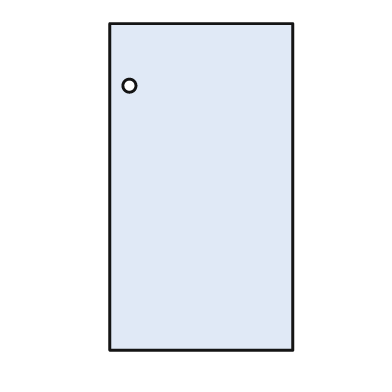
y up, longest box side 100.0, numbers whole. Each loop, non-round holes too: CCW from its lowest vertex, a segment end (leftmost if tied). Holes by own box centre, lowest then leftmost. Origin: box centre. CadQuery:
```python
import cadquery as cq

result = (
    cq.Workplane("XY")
    .moveTo(-28.0, -50.0)
    .lineTo(28.0, -50.0)
    .lineTo(28.0, 50.0)
    .lineTo(-28.0, 50.0)
    .close()
    .moveTo(-22.0, 31.0)
    .circle(2.0)
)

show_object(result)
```